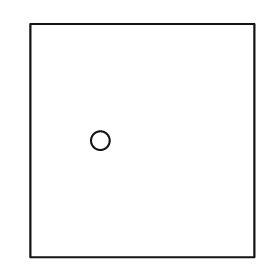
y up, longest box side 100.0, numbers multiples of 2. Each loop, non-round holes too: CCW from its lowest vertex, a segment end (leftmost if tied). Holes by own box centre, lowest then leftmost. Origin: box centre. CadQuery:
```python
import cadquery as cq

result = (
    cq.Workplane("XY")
    .moveTo(-48.0, -50.0)
    .lineTo(48.0, -50.0)
    .lineTo(48.0, 50.0)
    .lineTo(-48.0, 50.0)
    .close()
    .moveTo(-18.0, 0.0)
    .circle(4.0)
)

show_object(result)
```